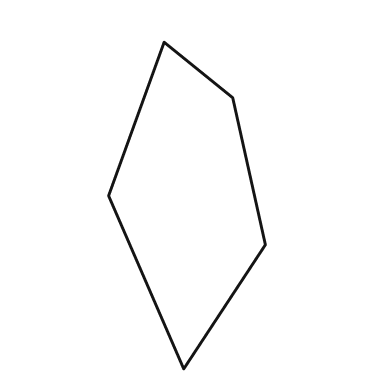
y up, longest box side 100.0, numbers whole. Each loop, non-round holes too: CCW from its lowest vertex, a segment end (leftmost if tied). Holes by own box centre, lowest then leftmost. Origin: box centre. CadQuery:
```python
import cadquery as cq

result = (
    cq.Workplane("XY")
    .moveTo(-1.0, -50.0)
    .lineTo(24.0, -12.0)
    .lineTo(14.0, 33.0)
    .lineTo(-7.0, 50.0)
    .lineTo(-24.0, 3.0)
    .close()
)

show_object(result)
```